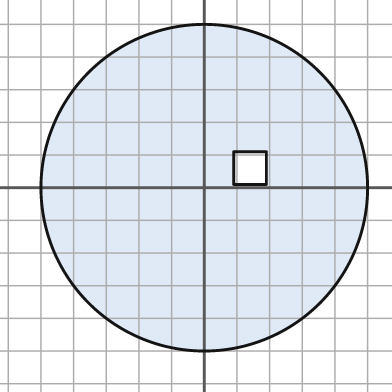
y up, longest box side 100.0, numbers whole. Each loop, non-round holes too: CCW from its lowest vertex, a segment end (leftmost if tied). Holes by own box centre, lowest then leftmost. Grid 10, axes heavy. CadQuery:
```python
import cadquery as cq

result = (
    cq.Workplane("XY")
    .moveTo(0.0, 0.0)
    .circle(50.0)
    .moveTo(9.0, 1.0)
    .lineTo(19.0, 1.0)
    .lineTo(19.0, 11.0)
    .lineTo(9.0, 11.0)
    .close()
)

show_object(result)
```